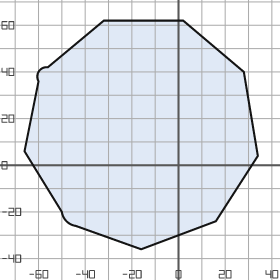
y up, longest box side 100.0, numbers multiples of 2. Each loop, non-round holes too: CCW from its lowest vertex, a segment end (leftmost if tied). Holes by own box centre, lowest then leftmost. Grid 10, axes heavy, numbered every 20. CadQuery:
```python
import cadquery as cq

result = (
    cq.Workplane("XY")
    .moveTo(-16.0, -36.0)
    .lineTo(16.0, -24.0)
    .lineTo(34.0, 4.0)
    .lineTo(28.0, 40.0)
    .lineTo(2.0, 62.0)
    .lineTo(-32.0, 62.0)
    .lineTo(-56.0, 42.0)
    .threePointArc((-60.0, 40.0), (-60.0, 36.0))
    .lineTo(-66.0, 6.0)
    .lineTo(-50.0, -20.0)
    .threePointArc((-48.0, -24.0), (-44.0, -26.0))
    .close()
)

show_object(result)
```